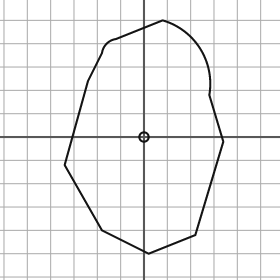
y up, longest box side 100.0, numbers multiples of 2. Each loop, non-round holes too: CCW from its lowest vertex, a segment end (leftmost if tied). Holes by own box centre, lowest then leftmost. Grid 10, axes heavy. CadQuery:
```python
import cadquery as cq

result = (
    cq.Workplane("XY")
    .moveTo(2.0, -50.0)
    .lineTo(22.0, -42.0)
    .lineTo(34.0, -2.0)
    .lineTo(28.0, 18.0)
    .threePointArc((24.0, 38.0), (8.0, 50.0))
    .lineTo(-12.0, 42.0)
    .threePointArc((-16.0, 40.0), (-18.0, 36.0))
    .lineTo(-24.0, 24.0)
    .lineTo(-34.0, -12.0)
    .lineTo(-18.0, -40.0)
    .close()
    .moveTo(0.0, 0.0)
    .circle(2.0)
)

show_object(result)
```